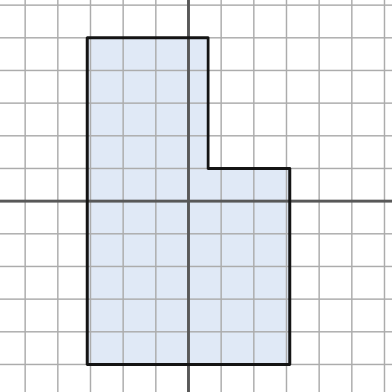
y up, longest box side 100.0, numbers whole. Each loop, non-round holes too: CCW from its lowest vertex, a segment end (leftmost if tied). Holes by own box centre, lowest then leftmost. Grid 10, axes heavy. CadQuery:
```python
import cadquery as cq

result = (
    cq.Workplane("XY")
    .moveTo(-31.0, -50.0)
    .lineTo(31.0, -50.0)
    .lineTo(31.0, 10.0)
    .lineTo(6.0, 10.0)
    .lineTo(6.0, 50.0)
    .lineTo(-31.0, 50.0)
    .close()
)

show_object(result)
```